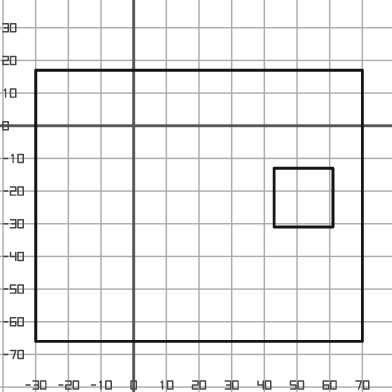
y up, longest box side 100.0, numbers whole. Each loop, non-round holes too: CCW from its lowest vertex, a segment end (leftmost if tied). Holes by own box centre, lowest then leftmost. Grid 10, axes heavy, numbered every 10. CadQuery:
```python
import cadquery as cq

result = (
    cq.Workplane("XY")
    .moveTo(-30.0, -66.0)
    .lineTo(70.0, -66.0)
    .lineTo(70.0, 17.0)
    .lineTo(-30.0, 17.0)
    .close()
    .moveTo(43.0, -31.0)
    .lineTo(61.0, -31.0)
    .lineTo(61.0, -13.0)
    .lineTo(43.0, -13.0)
    .close()
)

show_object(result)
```